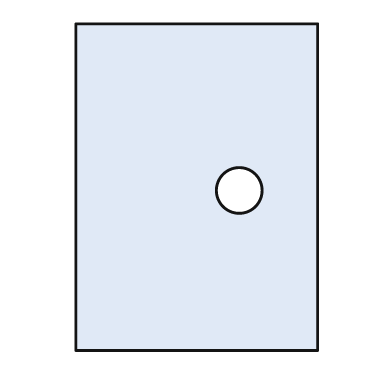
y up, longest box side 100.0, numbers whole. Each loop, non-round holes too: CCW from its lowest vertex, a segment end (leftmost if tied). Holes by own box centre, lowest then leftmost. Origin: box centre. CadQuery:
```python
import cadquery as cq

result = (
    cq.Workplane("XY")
    .moveTo(-37.0, -50.0)
    .lineTo(37.0, -50.0)
    .lineTo(37.0, 50.0)
    .lineTo(-37.0, 50.0)
    .close()
    .moveTo(13.0, -1.0)
    .circle(7.0)
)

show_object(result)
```